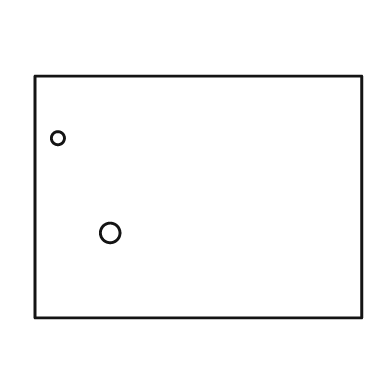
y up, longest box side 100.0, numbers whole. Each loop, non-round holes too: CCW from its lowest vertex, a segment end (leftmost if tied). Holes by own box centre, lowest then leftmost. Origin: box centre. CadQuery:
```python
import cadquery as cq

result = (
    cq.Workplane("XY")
    .moveTo(-50.0, -37.0)
    .lineTo(50.0, -37.0)
    .lineTo(50.0, 37.0)
    .lineTo(-50.0, 37.0)
    .close()
    .moveTo(-27.0, -11.0)
    .circle(3.0)
    .moveTo(-43.0, 18.0)
    .circle(2.0)
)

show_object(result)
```